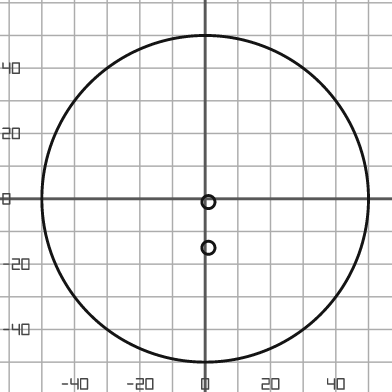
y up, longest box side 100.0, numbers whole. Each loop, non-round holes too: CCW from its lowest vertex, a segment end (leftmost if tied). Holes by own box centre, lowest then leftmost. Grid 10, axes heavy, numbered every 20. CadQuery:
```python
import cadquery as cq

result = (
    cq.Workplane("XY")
    .moveTo(0.0, 0.0)
    .circle(50.0)
    .moveTo(1.0, -15.0)
    .circle(2.0)
    .moveTo(1.0, -1.0)
    .circle(2.0)
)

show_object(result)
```